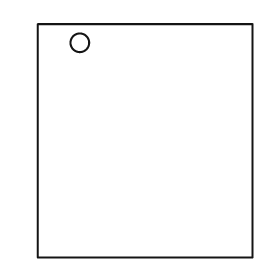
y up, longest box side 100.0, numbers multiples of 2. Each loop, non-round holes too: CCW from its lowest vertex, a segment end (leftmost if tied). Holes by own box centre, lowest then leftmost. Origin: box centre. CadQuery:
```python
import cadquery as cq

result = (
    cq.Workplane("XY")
    .moveTo(-46.0, -50.0)
    .lineTo(46.0, -50.0)
    .lineTo(46.0, 50.0)
    .lineTo(-46.0, 50.0)
    .close()
    .moveTo(-28.0, 42.0)
    .circle(4.0)
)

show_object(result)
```